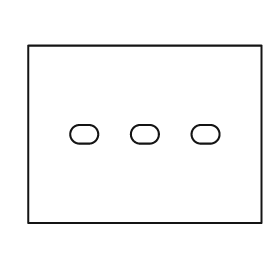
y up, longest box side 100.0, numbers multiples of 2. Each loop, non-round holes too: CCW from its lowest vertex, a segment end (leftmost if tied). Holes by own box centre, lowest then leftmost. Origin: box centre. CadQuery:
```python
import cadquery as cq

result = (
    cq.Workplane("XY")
    .moveTo(-50.0, -38.0)
    .lineTo(50.0, -38.0)
    .lineTo(50.0, 38.0)
    .lineTo(-50.0, 38.0)
    .close()
    .moveTo(-28.0, -4.0)
    .lineTo(-24.0, -4.0)
    .threePointArc((-20.0, 0.0), (-24.0, 4.0))
    .lineTo(-28.0, 4.0)
    .threePointArc((-32.0, 0.0), (-28.0, -4.0))
    .close()
    .moveTo(-2.0, -4.0)
    .lineTo(2.0, -4.0)
    .threePointArc((6.0, 0.0), (2.0, 4.0))
    .lineTo(-2.0, 4.0)
    .threePointArc((-6.0, 0.0), (-2.0, -4.0))
    .close()
    .moveTo(24.0, -4.0)
    .lineTo(28.0, -4.0)
    .threePointArc((32.0, 0.0), (28.0, 4.0))
    .lineTo(24.0, 4.0)
    .threePointArc((20.0, 0.0), (24.0, -4.0))
    .close()
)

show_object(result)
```